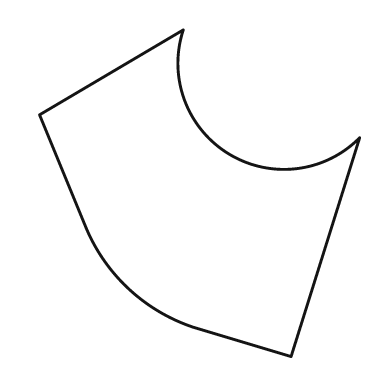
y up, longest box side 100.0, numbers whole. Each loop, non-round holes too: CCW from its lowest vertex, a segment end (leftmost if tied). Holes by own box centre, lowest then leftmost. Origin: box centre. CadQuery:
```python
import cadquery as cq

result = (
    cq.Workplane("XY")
    .moveTo(28.0, -50.0)
    .lineTo(49.0, 17.0)
    .threePointArc((9.0, 12.0), (-5.0, 50.0))
    .lineTo(-49.0, 24.0)
    .lineTo(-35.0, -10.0)
    .threePointArc((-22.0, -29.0), (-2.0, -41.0))
    .close()
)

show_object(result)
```